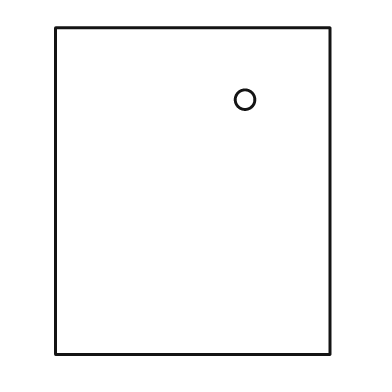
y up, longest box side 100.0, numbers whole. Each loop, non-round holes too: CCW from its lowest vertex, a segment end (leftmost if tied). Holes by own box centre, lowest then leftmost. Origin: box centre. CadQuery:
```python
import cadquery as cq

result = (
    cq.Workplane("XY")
    .moveTo(-42.0, -50.0)
    .lineTo(42.0, -50.0)
    .lineTo(42.0, 50.0)
    .lineTo(-42.0, 50.0)
    .close()
    .moveTo(16.0, 28.0)
    .circle(3.0)
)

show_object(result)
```